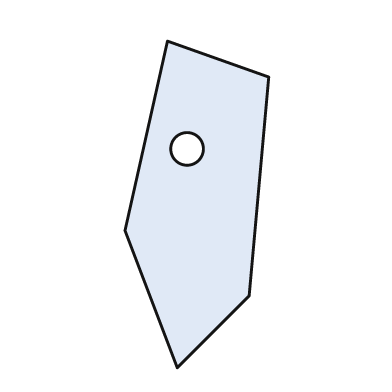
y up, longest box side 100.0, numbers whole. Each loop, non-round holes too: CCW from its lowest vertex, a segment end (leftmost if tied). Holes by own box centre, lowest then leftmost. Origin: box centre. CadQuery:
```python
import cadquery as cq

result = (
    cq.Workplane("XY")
    .moveTo(-6.0, -50.0)
    .lineTo(16.0, -28.0)
    .lineTo(22.0, 39.0)
    .lineTo(-9.0, 50.0)
    .lineTo(-22.0, -8.0)
    .close()
    .moveTo(-3.0, 17.0)
    .circle(5.0)
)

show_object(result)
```